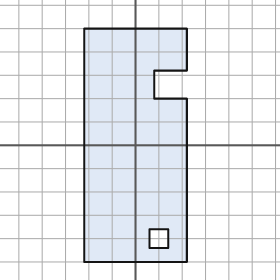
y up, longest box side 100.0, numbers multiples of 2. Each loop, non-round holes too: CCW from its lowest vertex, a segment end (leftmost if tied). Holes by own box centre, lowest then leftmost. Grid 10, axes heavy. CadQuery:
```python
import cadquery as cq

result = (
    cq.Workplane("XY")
    .moveTo(-22.0, -50.0)
    .lineTo(22.0, -50.0)
    .lineTo(22.0, 20.0)
    .lineTo(8.0, 20.0)
    .lineTo(8.0, 32.0)
    .lineTo(22.0, 32.0)
    .lineTo(22.0, 50.0)
    .lineTo(-22.0, 50.0)
    .close()
    .moveTo(6.0, -44.0)
    .lineTo(14.0, -44.0)
    .lineTo(14.0, -36.0)
    .lineTo(6.0, -36.0)
    .close()
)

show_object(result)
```